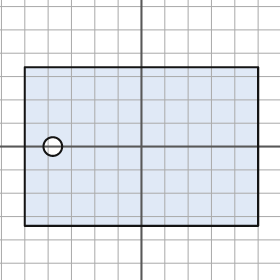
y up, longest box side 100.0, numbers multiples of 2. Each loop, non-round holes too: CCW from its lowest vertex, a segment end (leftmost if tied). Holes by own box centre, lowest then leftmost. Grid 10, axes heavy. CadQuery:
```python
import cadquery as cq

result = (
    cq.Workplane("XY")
    .moveTo(-50.0, -34.0)
    .lineTo(50.0, -34.0)
    .lineTo(50.0, 34.0)
    .lineTo(-50.0, 34.0)
    .close()
    .moveTo(-38.0, 0.0)
    .circle(4.0)
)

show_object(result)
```